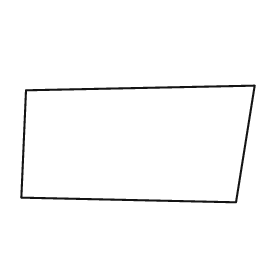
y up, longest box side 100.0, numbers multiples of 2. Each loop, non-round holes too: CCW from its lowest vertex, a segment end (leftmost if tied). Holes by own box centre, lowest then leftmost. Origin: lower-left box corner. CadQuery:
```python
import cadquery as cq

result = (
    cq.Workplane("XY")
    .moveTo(92.0, 0.0)
    .lineTo(100.0, 50.0)
    .lineTo(2.0, 48.0)
    .lineTo(0.0, 2.0)
    .close()
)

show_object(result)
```